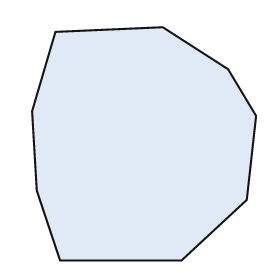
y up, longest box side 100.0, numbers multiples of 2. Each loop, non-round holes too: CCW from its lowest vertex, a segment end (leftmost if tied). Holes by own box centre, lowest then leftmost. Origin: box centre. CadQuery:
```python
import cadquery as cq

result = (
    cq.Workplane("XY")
    .moveTo(-36.0, -50.0)
    .lineTo(16.0, -50.0)
    .lineTo(44.0, -24.0)
    .lineTo(48.0, 12.0)
    .lineTo(36.0, 32.0)
    .lineTo(8.0, 50.0)
    .lineTo(-38.0, 48.0)
    .lineTo(-48.0, 14.0)
    .lineTo(-46.0, -20.0)
    .close()
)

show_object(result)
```